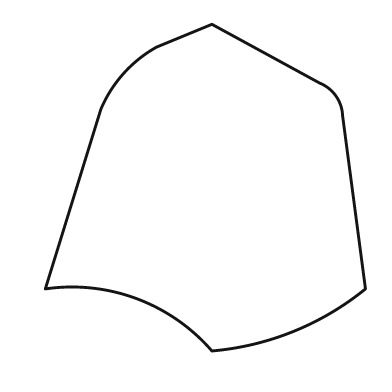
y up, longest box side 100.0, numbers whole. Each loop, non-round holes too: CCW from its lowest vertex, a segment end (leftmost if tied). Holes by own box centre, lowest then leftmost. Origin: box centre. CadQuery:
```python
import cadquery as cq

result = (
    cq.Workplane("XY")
    .moveTo(2.0, -50.0)
    .threePointArc((27.0, -44.0), (49.0, -31.0))
    .lineTo(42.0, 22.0)
    .threePointArc((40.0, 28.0), (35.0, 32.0))
    .lineTo(2.0, 50.0)
    .lineTo(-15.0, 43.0)
    .threePointArc((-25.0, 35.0), (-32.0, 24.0))
    .lineTo(-49.0, -31.0)
    .threePointArc((-21.0, -34.0), (2.0, -50.0))
    .close()
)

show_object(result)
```